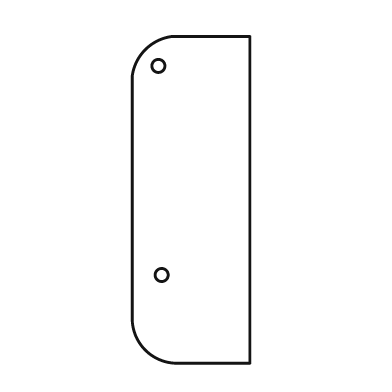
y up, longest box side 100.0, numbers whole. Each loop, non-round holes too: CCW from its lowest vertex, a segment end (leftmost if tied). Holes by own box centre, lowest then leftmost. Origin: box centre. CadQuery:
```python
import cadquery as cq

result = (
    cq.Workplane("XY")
    .moveTo(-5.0, -50.0)
    .lineTo(18.0, -50.0)
    .lineTo(18.0, 50.0)
    .lineTo(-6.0, 50.0)
    .threePointArc((-14.0, 46.0), (-18.0, 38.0))
    .lineTo(-18.0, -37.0)
    .threePointArc((-14.0, -46.0), (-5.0, -50.0))
    .close()
    .moveTo(-9.0, -23.0)
    .circle(2.0)
    .moveTo(-10.0, 41.0)
    .circle(2.0)
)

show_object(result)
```